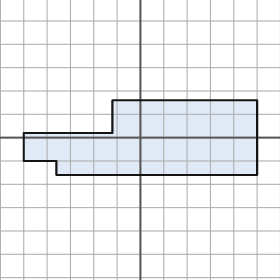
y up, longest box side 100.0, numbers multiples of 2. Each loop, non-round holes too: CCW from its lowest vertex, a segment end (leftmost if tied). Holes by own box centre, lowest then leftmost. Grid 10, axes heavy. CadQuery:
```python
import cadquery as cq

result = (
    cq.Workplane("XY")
    .moveTo(-36.0, -16.0)
    .lineTo(50.0, -16.0)
    .lineTo(50.0, 16.0)
    .lineTo(-12.0, 16.0)
    .lineTo(-12.0, 2.0)
    .lineTo(-50.0, 2.0)
    .lineTo(-50.0, -10.0)
    .lineTo(-36.0, -10.0)
    .close()
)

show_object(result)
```